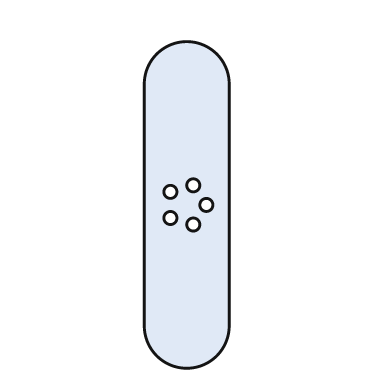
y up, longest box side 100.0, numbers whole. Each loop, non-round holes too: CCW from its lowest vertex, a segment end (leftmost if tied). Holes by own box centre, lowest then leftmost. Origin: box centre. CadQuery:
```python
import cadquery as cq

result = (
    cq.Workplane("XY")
    .moveTo(-13.0, -37.0)
    .threePointArc((0.0, -50.0), (13.0, -37.0))
    .lineTo(13.0, 37.0)
    .threePointArc((0.0, 50.0), (-13.0, 37.0))
    .close()
    .moveTo(2.0, -6.0)
    .circle(2.0)
    .moveTo(-5.0, -4.0)
    .circle(2.0)
    .moveTo(6.0, 0.0)
    .circle(2.0)
    .moveTo(-5.0, 4.0)
    .circle(2.0)
    .moveTo(2.0, 6.0)
    .circle(2.0)
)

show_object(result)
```